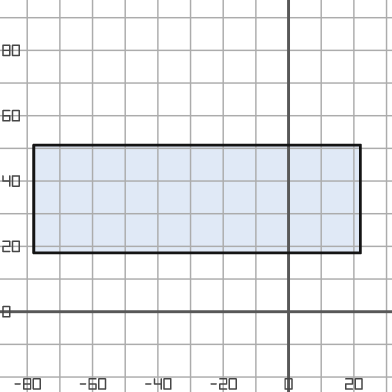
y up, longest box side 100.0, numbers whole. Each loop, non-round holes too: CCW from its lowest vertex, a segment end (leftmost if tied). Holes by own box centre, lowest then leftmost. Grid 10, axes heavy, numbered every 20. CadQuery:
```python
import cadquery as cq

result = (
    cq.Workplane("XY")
    .moveTo(-78.0, 18.0)
    .lineTo(22.0, 18.0)
    .lineTo(22.0, 51.0)
    .lineTo(-78.0, 51.0)
    .close()
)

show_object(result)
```